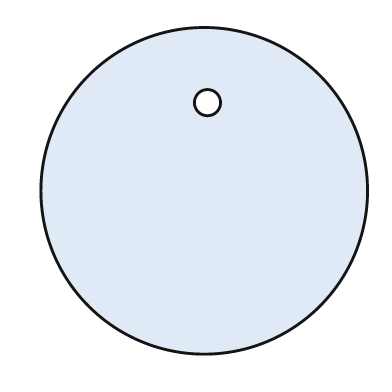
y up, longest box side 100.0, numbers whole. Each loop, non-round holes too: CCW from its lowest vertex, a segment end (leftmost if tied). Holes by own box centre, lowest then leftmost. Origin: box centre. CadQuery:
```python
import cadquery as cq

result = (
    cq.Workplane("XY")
    .moveTo(0.0, 0.0)
    .circle(50.0)
    .moveTo(1.0, 27.0)
    .circle(4.0)
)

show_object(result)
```